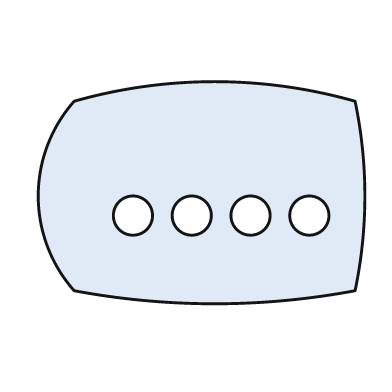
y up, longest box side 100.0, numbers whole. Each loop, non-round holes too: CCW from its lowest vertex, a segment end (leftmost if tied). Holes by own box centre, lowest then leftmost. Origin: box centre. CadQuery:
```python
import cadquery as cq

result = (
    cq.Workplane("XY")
    .moveTo(-39.0, -30.0)
    .threePointArc((4.0, -34.0), (47.0, -30.0))
    .threePointArc((50.0, -1.0), (47.0, 28.0))
    .threePointArc((4.0, 34.0), (-39.0, 28.0))
    .threePointArc((-50.0, -1.0), (-39.0, -30.0))
    .close()
    .moveTo(-21.0, -7.0)
    .circle(6.0)
    .moveTo(-3.0, -7.0)
    .circle(6.0)
    .moveTo(15.0, -7.0)
    .circle(6.0)
    .moveTo(33.0, -7.0)
    .circle(6.0)
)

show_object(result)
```